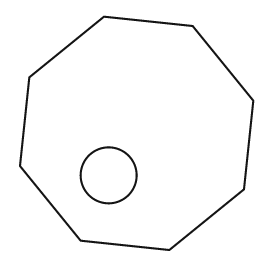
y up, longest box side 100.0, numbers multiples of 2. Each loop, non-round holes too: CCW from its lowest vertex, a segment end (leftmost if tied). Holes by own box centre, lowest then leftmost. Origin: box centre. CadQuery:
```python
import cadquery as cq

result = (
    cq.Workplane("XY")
    .moveTo(14.0, -50.0)
    .lineTo(46.0, -24.0)
    .lineTo(50.0, 14.0)
    .lineTo(24.0, 46.0)
    .lineTo(-14.0, 50.0)
    .lineTo(-46.0, 24.0)
    .lineTo(-50.0, -14.0)
    .lineTo(-24.0, -46.0)
    .close()
    .moveTo(-12.0, -18.0)
    .circle(12.0)
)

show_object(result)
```